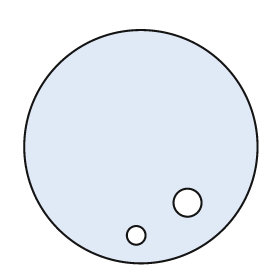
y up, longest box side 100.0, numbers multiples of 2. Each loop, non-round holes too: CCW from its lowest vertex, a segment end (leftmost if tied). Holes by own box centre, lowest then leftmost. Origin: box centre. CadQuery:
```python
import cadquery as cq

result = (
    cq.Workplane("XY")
    .moveTo(0.0, 0.0)
    .circle(50.0)
    .moveTo(-2.0, -38.0)
    .circle(4.0)
    .moveTo(20.0, -24.0)
    .circle(6.0)
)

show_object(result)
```